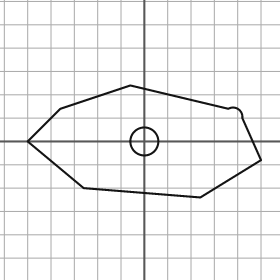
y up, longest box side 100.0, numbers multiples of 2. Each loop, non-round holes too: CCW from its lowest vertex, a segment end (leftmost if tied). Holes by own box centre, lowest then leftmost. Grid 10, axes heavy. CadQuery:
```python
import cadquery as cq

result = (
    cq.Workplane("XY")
    .moveTo(24.0, -24.0)
    .lineTo(50.0, -8.0)
    .lineTo(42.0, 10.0)
    .threePointArc((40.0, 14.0), (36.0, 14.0))
    .lineTo(-6.0, 24.0)
    .lineTo(-36.0, 14.0)
    .lineTo(-50.0, 0.0)
    .lineTo(-26.0, -20.0)
    .close()
    .moveTo(0.0, 0.0)
    .circle(6.0)
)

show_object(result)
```